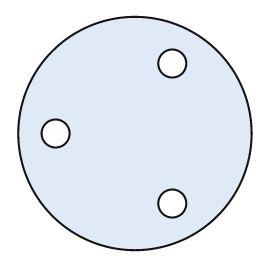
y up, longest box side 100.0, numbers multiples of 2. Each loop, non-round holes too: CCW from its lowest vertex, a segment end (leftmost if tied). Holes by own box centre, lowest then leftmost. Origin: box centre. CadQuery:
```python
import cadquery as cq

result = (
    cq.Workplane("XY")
    .moveTo(0.0, 0.0)
    .circle(50.0)
    .moveTo(16.0, -30.0)
    .circle(6.0)
    .moveTo(-34.0, 0.0)
    .circle(6.0)
    .moveTo(16.0, 30.0)
    .circle(6.0)
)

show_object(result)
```